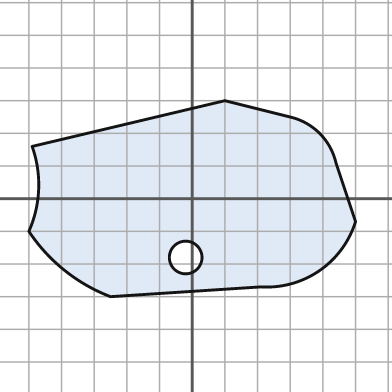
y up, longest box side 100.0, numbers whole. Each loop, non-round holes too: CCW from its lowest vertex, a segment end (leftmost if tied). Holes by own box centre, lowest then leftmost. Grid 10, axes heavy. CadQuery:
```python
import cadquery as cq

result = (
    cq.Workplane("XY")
    .moveTo(-25.0, -30.0)
    .lineTo(21.0, -27.0)
    .threePointArc((39.0, -22.0), (50.0, -7.0))
    .lineTo(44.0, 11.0)
    .threePointArc((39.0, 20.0), (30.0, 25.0))
    .lineTo(10.0, 30.0)
    .lineTo(-49.0, 16.0)
    .threePointArc((-47.0, 3.0), (-50.0, -10.0))
    .threePointArc((-39.0, -22.0), (-25.0, -30.0))
    .close()
    .moveTo(-2.0, -18.0)
    .circle(5.0)
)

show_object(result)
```